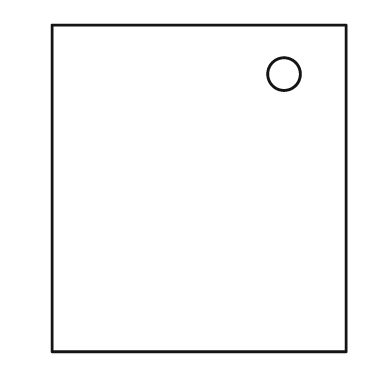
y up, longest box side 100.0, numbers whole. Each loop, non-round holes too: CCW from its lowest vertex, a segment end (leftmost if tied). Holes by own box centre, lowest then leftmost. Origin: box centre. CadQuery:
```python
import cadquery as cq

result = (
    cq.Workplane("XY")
    .moveTo(-45.0, -50.0)
    .lineTo(45.0, -50.0)
    .lineTo(45.0, 50.0)
    .lineTo(-45.0, 50.0)
    .close()
    .moveTo(26.0, 35.0)
    .circle(5.0)
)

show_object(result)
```